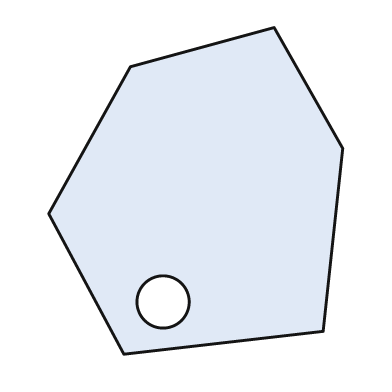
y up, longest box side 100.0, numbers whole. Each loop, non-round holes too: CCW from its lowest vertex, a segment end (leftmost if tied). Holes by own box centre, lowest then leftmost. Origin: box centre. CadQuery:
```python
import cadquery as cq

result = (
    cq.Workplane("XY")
    .moveTo(-22.0, -50.0)
    .lineTo(39.0, -43.0)
    .lineTo(45.0, 13.0)
    .lineTo(24.0, 50.0)
    .lineTo(-20.0, 38.0)
    .lineTo(-45.0, -7.0)
    .close()
    .moveTo(-10.0, -34.0)
    .circle(8.0)
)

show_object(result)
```